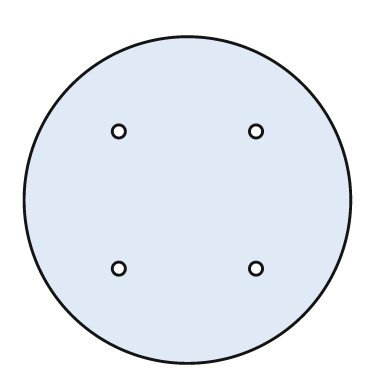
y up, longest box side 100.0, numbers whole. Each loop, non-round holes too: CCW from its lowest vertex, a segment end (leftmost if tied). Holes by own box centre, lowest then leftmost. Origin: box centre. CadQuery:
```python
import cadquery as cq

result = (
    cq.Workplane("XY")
    .moveTo(0.0, 0.0)
    .circle(50.0)
    .moveTo(-21.0, -21.0)
    .circle(2.0)
    .moveTo(21.0, -21.0)
    .circle(2.0)
    .moveTo(-21.0, 21.0)
    .circle(2.0)
    .moveTo(21.0, 21.0)
    .circle(2.0)
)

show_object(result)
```